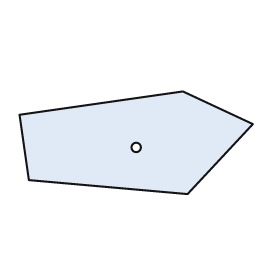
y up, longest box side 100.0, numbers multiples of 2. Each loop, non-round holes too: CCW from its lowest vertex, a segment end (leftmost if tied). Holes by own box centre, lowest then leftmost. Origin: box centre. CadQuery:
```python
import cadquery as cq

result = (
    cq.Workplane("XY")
    .moveTo(22.0, -22.0)
    .lineTo(50.0, 8.0)
    .lineTo(20.0, 22.0)
    .lineTo(-50.0, 12.0)
    .lineTo(-46.0, -16.0)
    .close()
    .moveTo(0.0, -2.0)
    .circle(2.0)
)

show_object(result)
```